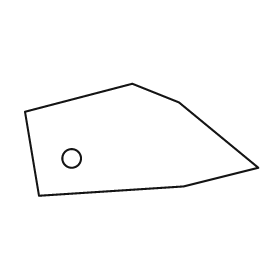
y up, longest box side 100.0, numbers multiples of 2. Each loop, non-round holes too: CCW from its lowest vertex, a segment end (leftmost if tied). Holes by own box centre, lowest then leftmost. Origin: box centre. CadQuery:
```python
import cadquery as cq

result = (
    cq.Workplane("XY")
    .moveTo(-44.0, -24.0)
    .lineTo(18.0, -20.0)
    .lineTo(50.0, -12.0)
    .lineTo(16.0, 16.0)
    .lineTo(-4.0, 24.0)
    .lineTo(-50.0, 12.0)
    .close()
    .moveTo(-30.0, -8.0)
    .circle(4.0)
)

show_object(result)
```